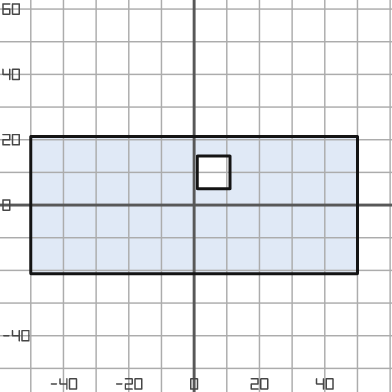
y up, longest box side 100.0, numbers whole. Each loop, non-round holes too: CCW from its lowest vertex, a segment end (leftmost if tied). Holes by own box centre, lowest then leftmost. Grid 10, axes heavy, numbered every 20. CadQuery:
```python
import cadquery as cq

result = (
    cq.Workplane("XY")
    .moveTo(-50.0, -21.0)
    .lineTo(50.0, -21.0)
    .lineTo(50.0, 21.0)
    .lineTo(-50.0, 21.0)
    .close()
    .moveTo(1.0, 5.0)
    .lineTo(11.0, 5.0)
    .lineTo(11.0, 15.0)
    .lineTo(1.0, 15.0)
    .close()
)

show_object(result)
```